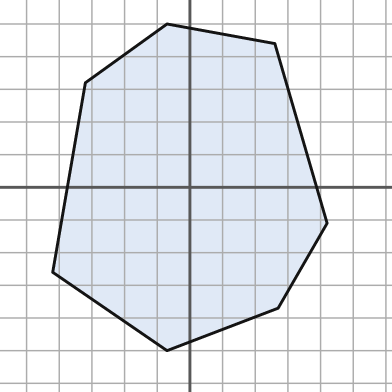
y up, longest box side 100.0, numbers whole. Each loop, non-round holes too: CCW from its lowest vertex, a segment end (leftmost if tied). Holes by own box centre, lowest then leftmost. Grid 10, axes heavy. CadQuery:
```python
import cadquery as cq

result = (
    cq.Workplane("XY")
    .moveTo(-7.0, -50.0)
    .lineTo(27.0, -37.0)
    .lineTo(42.0, -11.0)
    .lineTo(26.0, 44.0)
    .lineTo(-7.0, 50.0)
    .lineTo(-32.0, 32.0)
    .lineTo(-42.0, -26.0)
    .close()
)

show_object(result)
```